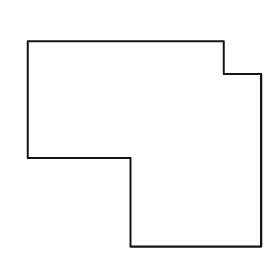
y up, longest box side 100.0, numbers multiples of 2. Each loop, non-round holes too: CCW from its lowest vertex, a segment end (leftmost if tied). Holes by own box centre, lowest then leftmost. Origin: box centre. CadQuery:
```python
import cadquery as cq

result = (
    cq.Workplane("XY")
    .moveTo(-6.0, -44.0)
    .lineTo(50.0, -44.0)
    .lineTo(50.0, 30.0)
    .lineTo(34.0, 30.0)
    .lineTo(34.0, 44.0)
    .lineTo(-50.0, 44.0)
    .lineTo(-50.0, -6.0)
    .lineTo(-6.0, -6.0)
    .close()
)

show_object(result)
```